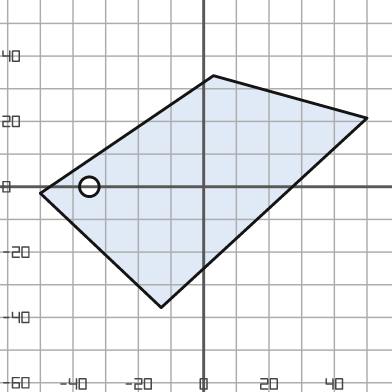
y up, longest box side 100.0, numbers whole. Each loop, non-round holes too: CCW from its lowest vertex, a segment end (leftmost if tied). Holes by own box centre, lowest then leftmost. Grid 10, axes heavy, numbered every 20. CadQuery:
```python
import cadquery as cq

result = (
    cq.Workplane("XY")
    .moveTo(-13.0, -37.0)
    .lineTo(50.0, 21.0)
    .lineTo(3.0, 34.0)
    .lineTo(-50.0, -2.0)
    .close()
    .moveTo(-35.0, 0.0)
    .circle(3.0)
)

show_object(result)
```